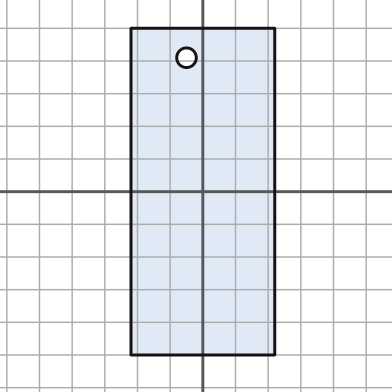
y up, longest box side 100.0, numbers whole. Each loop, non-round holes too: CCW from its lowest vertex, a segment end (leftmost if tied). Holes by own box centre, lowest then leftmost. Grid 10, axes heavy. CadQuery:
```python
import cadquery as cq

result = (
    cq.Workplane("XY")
    .moveTo(-22.0, -50.0)
    .lineTo(22.0, -50.0)
    .lineTo(22.0, 50.0)
    .lineTo(-22.0, 50.0)
    .close()
    .moveTo(-5.0, 41.0)
    .circle(3.0)
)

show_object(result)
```